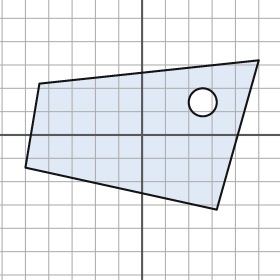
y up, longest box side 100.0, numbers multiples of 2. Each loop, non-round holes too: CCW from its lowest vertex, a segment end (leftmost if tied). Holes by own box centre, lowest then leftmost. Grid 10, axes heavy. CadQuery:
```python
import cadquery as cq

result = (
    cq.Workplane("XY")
    .moveTo(32.0, -32.0)
    .lineTo(50.0, 32.0)
    .lineTo(-44.0, 22.0)
    .lineTo(-50.0, -14.0)
    .close()
    .moveTo(26.0, 14.0)
    .circle(6.0)
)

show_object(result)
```